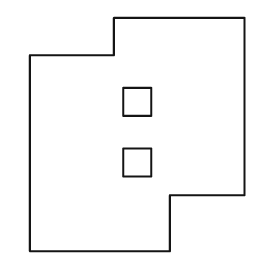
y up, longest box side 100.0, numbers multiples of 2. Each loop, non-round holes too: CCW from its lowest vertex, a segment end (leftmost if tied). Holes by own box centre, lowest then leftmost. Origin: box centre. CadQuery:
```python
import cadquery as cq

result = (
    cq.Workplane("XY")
    .moveTo(-46.0, -50.0)
    .lineTo(14.0, -50.0)
    .lineTo(14.0, -26.0)
    .lineTo(46.0, -26.0)
    .lineTo(46.0, 50.0)
    .lineTo(-10.0, 50.0)
    .lineTo(-10.0, 34.0)
    .lineTo(-46.0, 34.0)
    .close()
    .moveTo(-6.0, -18.0)
    .lineTo(6.0, -18.0)
    .lineTo(6.0, -6.0)
    .lineTo(-6.0, -6.0)
    .close()
    .moveTo(-6.0, 8.0)
    .lineTo(6.0, 8.0)
    .lineTo(6.0, 20.0)
    .lineTo(-6.0, 20.0)
    .close()
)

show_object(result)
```